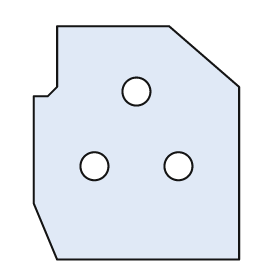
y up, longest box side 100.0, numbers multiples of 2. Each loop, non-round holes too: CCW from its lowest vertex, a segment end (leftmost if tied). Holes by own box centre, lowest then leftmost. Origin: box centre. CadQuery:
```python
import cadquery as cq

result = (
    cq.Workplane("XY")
    .moveTo(-34.0, -50.0)
    .lineTo(44.0, -50.0)
    .lineTo(44.0, 24.0)
    .lineTo(14.0, 50.0)
    .lineTo(-34.0, 50.0)
    .lineTo(-34.0, 24.0)
    .lineTo(-38.0, 20.0)
    .lineTo(-44.0, 20.0)
    .lineTo(-44.0, -26.0)
    .close()
    .moveTo(-18.0, -10.0)
    .circle(6.0)
    .moveTo(18.0, -10.0)
    .circle(6.0)
    .moveTo(0.0, 22.0)
    .circle(6.0)
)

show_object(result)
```